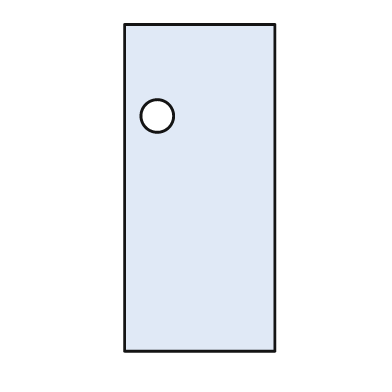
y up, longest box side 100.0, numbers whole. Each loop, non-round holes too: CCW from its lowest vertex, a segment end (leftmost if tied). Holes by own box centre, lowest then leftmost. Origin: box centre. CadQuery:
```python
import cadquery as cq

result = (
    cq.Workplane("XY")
    .moveTo(-23.0, -50.0)
    .lineTo(23.0, -50.0)
    .lineTo(23.0, 50.0)
    .lineTo(-23.0, 50.0)
    .close()
    .moveTo(-13.0, 22.0)
    .circle(5.0)
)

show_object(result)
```